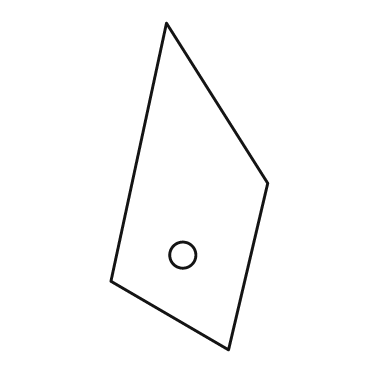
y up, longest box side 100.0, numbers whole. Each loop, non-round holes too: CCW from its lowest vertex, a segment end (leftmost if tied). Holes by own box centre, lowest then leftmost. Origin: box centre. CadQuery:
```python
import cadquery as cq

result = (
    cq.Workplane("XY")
    .moveTo(12.0, -50.0)
    .lineTo(24.0, 1.0)
    .lineTo(-7.0, 50.0)
    .lineTo(-24.0, -29.0)
    .close()
    .moveTo(-2.0, -21.0)
    .circle(4.0)
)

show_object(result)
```